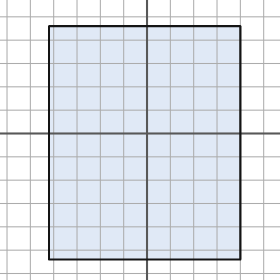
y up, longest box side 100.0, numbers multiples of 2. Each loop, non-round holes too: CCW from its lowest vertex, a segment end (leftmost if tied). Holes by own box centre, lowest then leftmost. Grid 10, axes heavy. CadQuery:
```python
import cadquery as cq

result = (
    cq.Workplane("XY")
    .moveTo(-42.0, -54.0)
    .lineTo(40.0, -54.0)
    .lineTo(40.0, 46.0)
    .lineTo(-42.0, 46.0)
    .close()
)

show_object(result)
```